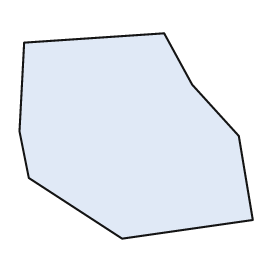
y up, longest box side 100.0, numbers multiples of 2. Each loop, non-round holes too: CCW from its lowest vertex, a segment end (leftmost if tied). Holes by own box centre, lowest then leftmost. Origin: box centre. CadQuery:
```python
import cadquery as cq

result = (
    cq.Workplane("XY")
    .moveTo(-6.0, -44.0)
    .lineTo(50.0, -36.0)
    .lineTo(44.0, 0.0)
    .lineTo(24.0, 22.0)
    .lineTo(12.0, 44.0)
    .lineTo(-48.0, 40.0)
    .lineTo(-50.0, 2.0)
    .lineTo(-46.0, -18.0)
    .close()
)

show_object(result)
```